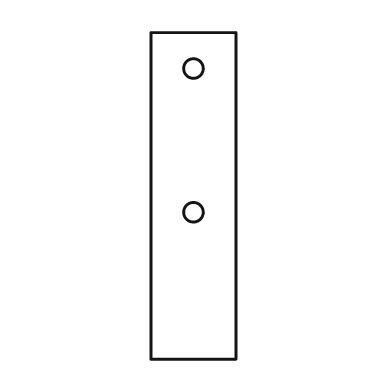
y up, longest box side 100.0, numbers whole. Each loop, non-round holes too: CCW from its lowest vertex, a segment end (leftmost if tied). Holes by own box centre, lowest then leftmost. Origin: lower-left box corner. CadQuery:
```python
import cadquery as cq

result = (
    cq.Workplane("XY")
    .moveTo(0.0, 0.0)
    .lineTo(26.0, 0.0)
    .lineTo(26.0, 100.0)
    .lineTo(0.0, 100.0)
    .close()
    .moveTo(13.0, 45.0)
    .circle(3.0)
    .moveTo(13.0, 89.0)
    .circle(3.0)
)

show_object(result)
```